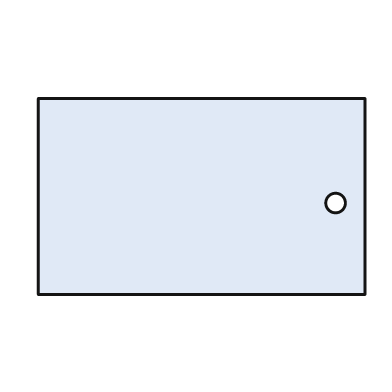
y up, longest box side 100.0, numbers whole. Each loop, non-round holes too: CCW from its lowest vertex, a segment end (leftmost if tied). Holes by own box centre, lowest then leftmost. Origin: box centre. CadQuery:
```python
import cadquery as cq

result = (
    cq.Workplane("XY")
    .moveTo(-50.0, -30.0)
    .lineTo(50.0, -30.0)
    .lineTo(50.0, 30.0)
    .lineTo(-50.0, 30.0)
    .close()
    .moveTo(41.0, -2.0)
    .circle(3.0)
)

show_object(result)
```